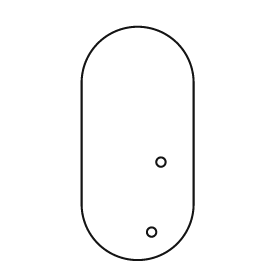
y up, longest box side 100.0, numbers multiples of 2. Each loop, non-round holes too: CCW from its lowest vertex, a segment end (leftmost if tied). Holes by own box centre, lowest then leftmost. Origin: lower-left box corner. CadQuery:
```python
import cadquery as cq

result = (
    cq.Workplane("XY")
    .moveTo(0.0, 24.0)
    .threePointArc((24.0, 0.0), (48.0, 24.0))
    .lineTo(48.0, 76.0)
    .threePointArc((24.0, 100.0), (0.0, 76.0))
    .close()
    .moveTo(30.0, 12.0)
    .circle(2.0)
    .moveTo(34.0, 42.0)
    .circle(2.0)
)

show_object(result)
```